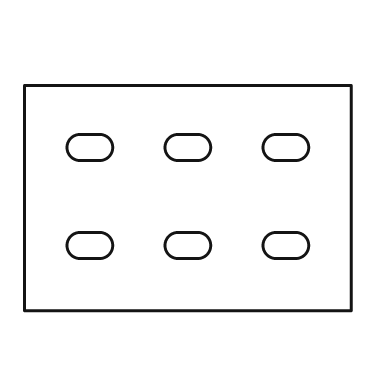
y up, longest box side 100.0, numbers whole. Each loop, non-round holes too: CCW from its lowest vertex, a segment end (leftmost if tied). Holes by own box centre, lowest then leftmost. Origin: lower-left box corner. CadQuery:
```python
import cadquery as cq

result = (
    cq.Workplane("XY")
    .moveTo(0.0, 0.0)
    .lineTo(100.0, 0.0)
    .lineTo(100.0, 69.0)
    .lineTo(0.0, 69.0)
    .close()
    .moveTo(17.0, 16.0)
    .lineTo(23.0, 16.0)
    .threePointArc((27.0, 20.0), (23.0, 24.0))
    .lineTo(17.0, 24.0)
    .threePointArc((13.0, 20.0), (17.0, 16.0))
    .close()
    .moveTo(47.0, 16.0)
    .lineTo(53.0, 16.0)
    .threePointArc((57.0, 20.0), (53.0, 24.0))
    .lineTo(47.0, 24.0)
    .threePointArc((43.0, 20.0), (47.0, 16.0))
    .close()
    .moveTo(77.0, 16.0)
    .lineTo(83.0, 16.0)
    .threePointArc((87.0, 20.0), (83.0, 24.0))
    .lineTo(77.0, 24.0)
    .threePointArc((73.0, 20.0), (77.0, 16.0))
    .close()
    .moveTo(17.0, 46.0)
    .lineTo(23.0, 46.0)
    .threePointArc((27.0, 50.0), (23.0, 54.0))
    .lineTo(17.0, 54.0)
    .threePointArc((13.0, 50.0), (17.0, 46.0))
    .close()
    .moveTo(47.0, 46.0)
    .lineTo(53.0, 46.0)
    .threePointArc((57.0, 50.0), (53.0, 54.0))
    .lineTo(47.0, 54.0)
    .threePointArc((43.0, 50.0), (47.0, 46.0))
    .close()
    .moveTo(77.0, 46.0)
    .lineTo(83.0, 46.0)
    .threePointArc((87.0, 50.0), (83.0, 54.0))
    .lineTo(77.0, 54.0)
    .threePointArc((73.0, 50.0), (77.0, 46.0))
    .close()
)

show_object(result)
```